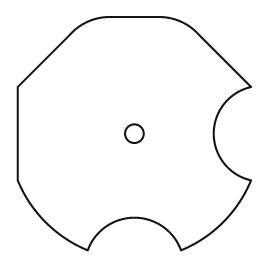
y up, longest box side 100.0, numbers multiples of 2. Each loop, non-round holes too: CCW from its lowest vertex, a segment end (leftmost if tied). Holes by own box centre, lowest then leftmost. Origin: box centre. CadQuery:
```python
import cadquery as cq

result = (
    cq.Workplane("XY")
    .moveTo(-20.0, -50.0)
    .threePointArc((0.0, -36.0), (20.0, -50.0))
    .threePointArc((38.0, -38.0), (50.0, -20.0))
    .threePointArc((34.0, 0.0), (50.0, 20.0))
    .lineTo(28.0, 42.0)
    .threePointArc((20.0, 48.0), (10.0, 50.0))
    .lineTo(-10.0, 50.0)
    .threePointArc((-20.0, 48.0), (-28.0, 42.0))
    .lineTo(-50.0, 20.0)
    .lineTo(-50.0, -20.0)
    .threePointArc((-38.0, -38.0), (-20.0, -50.0))
    .close()
    .moveTo(0.0, 0.0)
    .circle(4.0)
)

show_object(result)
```